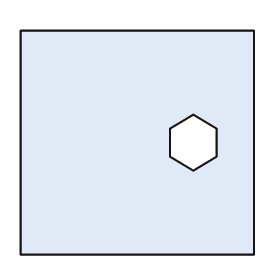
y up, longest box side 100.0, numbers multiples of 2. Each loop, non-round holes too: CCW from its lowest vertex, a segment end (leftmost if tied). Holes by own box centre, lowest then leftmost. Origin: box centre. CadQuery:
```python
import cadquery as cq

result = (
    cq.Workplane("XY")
    .moveTo(-50.0, -48.0)
    .lineTo(50.0, -48.0)
    .lineTo(50.0, 48.0)
    .lineTo(-50.0, 48.0)
    .close()
    .moveTo(24.0, -12.0)
    .lineTo(34.0, -6.0)
    .lineTo(34.0, 6.0)
    .lineTo(24.0, 12.0)
    .lineTo(14.0, 6.0)
    .lineTo(14.0, -6.0)
    .close()
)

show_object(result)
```